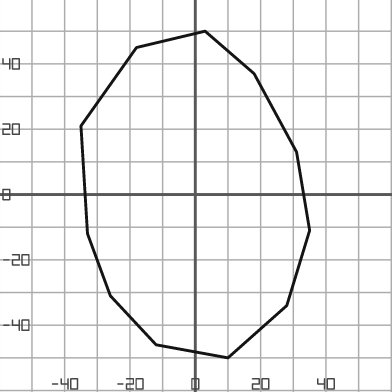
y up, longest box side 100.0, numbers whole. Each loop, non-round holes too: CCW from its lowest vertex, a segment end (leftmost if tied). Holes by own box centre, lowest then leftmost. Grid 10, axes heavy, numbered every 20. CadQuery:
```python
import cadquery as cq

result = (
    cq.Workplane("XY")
    .moveTo(10.0, -50.0)
    .lineTo(28.0, -34.0)
    .lineTo(35.0, -11.0)
    .lineTo(31.0, 13.0)
    .lineTo(18.0, 37.0)
    .lineTo(3.0, 50.0)
    .lineTo(-18.0, 45.0)
    .lineTo(-35.0, 21.0)
    .lineTo(-33.0, -12.0)
    .lineTo(-26.0, -31.0)
    .lineTo(-12.0, -46.0)
    .close()
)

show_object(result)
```